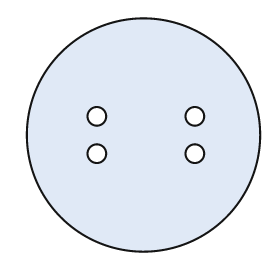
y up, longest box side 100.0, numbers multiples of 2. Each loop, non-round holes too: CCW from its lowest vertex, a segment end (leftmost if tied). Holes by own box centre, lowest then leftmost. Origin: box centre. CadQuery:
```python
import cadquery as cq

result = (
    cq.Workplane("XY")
    .moveTo(0.0, 0.0)
    .circle(50.0)
    .moveTo(-20.0, -8.0)
    .circle(4.0)
    .moveTo(22.0, -8.0)
    .circle(4.0)
    .moveTo(-20.0, 8.0)
    .circle(4.0)
    .moveTo(22.0, 8.0)
    .circle(4.0)
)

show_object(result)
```